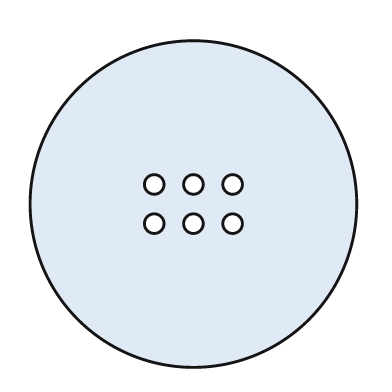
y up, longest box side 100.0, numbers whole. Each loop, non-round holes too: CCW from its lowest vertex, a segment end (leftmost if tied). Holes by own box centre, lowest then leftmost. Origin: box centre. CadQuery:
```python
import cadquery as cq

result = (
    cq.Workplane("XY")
    .moveTo(0.0, 0.0)
    .circle(50.0)
    .moveTo(-12.0, -6.0)
    .circle(3.0)
    .moveTo(0.0, -6.0)
    .circle(3.0)
    .moveTo(12.0, -6.0)
    .circle(3.0)
    .moveTo(-12.0, 6.0)
    .circle(3.0)
    .moveTo(0.0, 6.0)
    .circle(3.0)
    .moveTo(12.0, 6.0)
    .circle(3.0)
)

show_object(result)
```